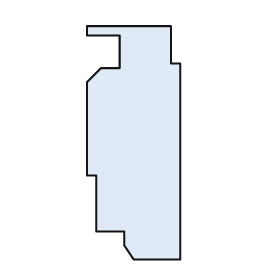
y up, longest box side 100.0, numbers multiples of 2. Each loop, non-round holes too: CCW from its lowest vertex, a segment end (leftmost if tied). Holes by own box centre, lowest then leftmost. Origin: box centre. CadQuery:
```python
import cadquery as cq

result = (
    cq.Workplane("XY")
    .moveTo(0.0, -50.0)
    .lineTo(20.0, -50.0)
    .lineTo(20.0, 34.0)
    .lineTo(16.0, 34.0)
    .lineTo(16.0, 50.0)
    .lineTo(-20.0, 50.0)
    .lineTo(-20.0, 46.0)
    .lineTo(-6.0, 46.0)
    .lineTo(-6.0, 32.0)
    .lineTo(-14.0, 32.0)
    .lineTo(-20.0, 26.0)
    .lineTo(-20.0, -14.0)
    .lineTo(-16.0, -14.0)
    .lineTo(-16.0, -38.0)
    .lineTo(-4.0, -38.0)
    .lineTo(-4.0, -44.0)
    .close()
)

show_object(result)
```